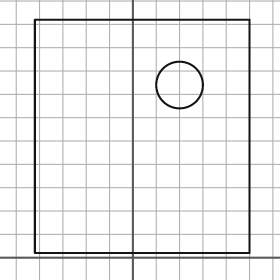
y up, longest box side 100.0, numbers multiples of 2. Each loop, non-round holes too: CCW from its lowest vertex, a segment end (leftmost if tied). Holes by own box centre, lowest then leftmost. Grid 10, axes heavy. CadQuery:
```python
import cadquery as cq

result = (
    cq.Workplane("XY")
    .moveTo(-42.0, 2.0)
    .lineTo(50.0, 2.0)
    .lineTo(50.0, 102.0)
    .lineTo(-42.0, 102.0)
    .close()
    .moveTo(20.0, 74.0)
    .circle(10.0)
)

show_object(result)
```